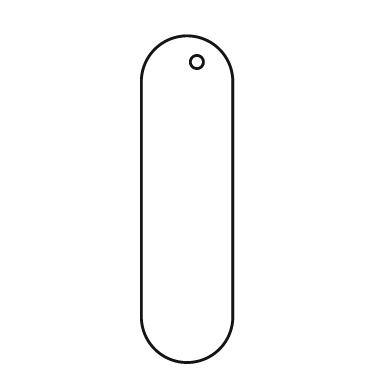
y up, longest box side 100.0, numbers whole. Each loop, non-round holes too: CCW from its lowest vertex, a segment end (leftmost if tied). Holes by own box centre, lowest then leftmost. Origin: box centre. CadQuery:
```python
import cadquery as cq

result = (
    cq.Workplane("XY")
    .moveTo(-14.0, -36.0)
    .threePointArc((0.0, -50.0), (14.0, -36.0))
    .lineTo(14.0, 36.0)
    .threePointArc((0.0, 50.0), (-14.0, 36.0))
    .close()
    .moveTo(3.0, 42.0)
    .circle(2.0)
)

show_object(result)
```